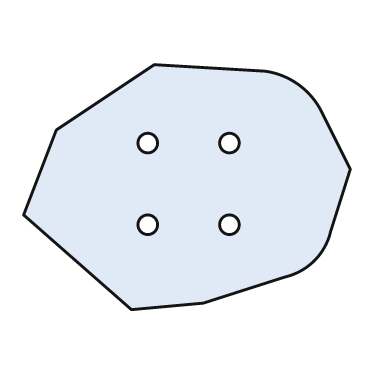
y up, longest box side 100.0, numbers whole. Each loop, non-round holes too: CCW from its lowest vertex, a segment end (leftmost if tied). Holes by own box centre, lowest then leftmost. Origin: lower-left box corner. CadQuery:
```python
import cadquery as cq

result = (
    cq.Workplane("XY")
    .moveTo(33.0, 0.0)
    .lineTo(55.0, 2.0)
    .lineTo(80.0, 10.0)
    .threePointArc((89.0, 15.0), (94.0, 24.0))
    .lineTo(100.0, 43.0)
    .lineTo(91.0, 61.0)
    .threePointArc((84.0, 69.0), (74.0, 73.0))
    .lineTo(40.0, 75.0)
    .lineTo(10.0, 55.0)
    .lineTo(0.0, 29.0)
    .close()
    .moveTo(38.0, 26.0)
    .circle(3.0)
    .moveTo(63.0, 26.0)
    .circle(3.0)
    .moveTo(38.0, 51.0)
    .circle(3.0)
    .moveTo(63.0, 51.0)
    .circle(3.0)
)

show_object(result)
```